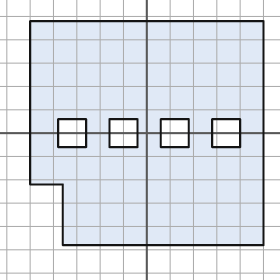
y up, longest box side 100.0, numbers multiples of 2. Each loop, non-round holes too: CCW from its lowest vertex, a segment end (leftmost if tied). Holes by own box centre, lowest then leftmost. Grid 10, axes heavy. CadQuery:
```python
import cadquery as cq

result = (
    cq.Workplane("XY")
    .moveTo(-36.0, -48.0)
    .lineTo(50.0, -48.0)
    .lineTo(50.0, 48.0)
    .lineTo(-50.0, 48.0)
    .lineTo(-50.0, -22.0)
    .lineTo(-36.0, -22.0)
    .close()
    .moveTo(-38.0, -6.0)
    .lineTo(-26.0, -6.0)
    .lineTo(-26.0, 6.0)
    .lineTo(-38.0, 6.0)
    .close()
    .moveTo(-16.0, -6.0)
    .lineTo(-4.0, -6.0)
    .lineTo(-4.0, 6.0)
    .lineTo(-16.0, 6.0)
    .close()
    .moveTo(6.0, -6.0)
    .lineTo(18.0, -6.0)
    .lineTo(18.0, 6.0)
    .lineTo(6.0, 6.0)
    .close()
    .moveTo(28.0, -6.0)
    .lineTo(40.0, -6.0)
    .lineTo(40.0, 6.0)
    .lineTo(28.0, 6.0)
    .close()
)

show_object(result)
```